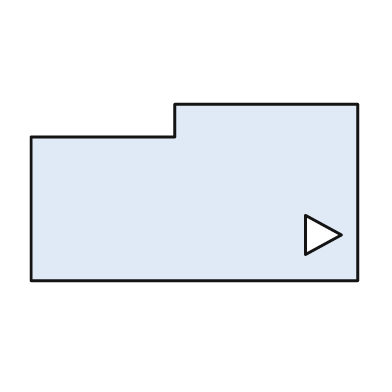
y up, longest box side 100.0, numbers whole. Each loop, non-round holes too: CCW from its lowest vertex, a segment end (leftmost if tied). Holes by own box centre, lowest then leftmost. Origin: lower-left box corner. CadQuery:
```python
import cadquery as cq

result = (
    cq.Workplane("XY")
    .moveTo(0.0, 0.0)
    .lineTo(100.0, 0.0)
    .lineTo(100.0, 54.0)
    .lineTo(44.0, 54.0)
    .lineTo(44.0, 44.0)
    .lineTo(0.0, 44.0)
    .close()
    .moveTo(84.0, 8.0)
    .lineTo(95.0, 14.0)
    .lineTo(84.0, 20.0)
    .close()
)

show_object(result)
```